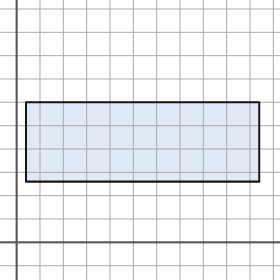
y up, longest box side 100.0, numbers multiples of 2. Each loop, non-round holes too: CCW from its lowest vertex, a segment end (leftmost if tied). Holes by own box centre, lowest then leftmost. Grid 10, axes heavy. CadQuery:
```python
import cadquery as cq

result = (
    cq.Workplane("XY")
    .moveTo(4.0, 26.0)
    .lineTo(104.0, 26.0)
    .lineTo(104.0, 60.0)
    .lineTo(4.0, 60.0)
    .close()
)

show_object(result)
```